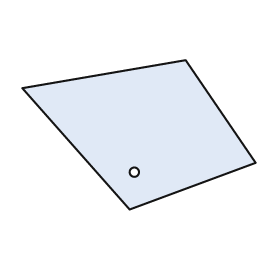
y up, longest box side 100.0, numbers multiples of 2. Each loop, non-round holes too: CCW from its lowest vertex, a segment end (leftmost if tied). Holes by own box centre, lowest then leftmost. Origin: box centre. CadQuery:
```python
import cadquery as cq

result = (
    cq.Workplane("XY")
    .moveTo(-4.0, -32.0)
    .lineTo(50.0, -12.0)
    .lineTo(20.0, 32.0)
    .lineTo(-50.0, 20.0)
    .close()
    .moveTo(-2.0, -16.0)
    .circle(2.0)
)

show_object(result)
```